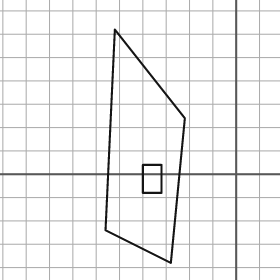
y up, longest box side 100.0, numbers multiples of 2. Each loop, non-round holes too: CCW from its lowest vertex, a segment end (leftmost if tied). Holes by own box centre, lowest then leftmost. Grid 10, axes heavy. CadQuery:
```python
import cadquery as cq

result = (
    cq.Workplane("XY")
    .moveTo(-28.0, -38.0)
    .lineTo(-22.0, 24.0)
    .lineTo(-52.0, 62.0)
    .lineTo(-56.0, -24.0)
    .close()
    .moveTo(-40.0, -8.0)
    .lineTo(-32.0, -8.0)
    .lineTo(-32.0, 4.0)
    .lineTo(-40.0, 4.0)
    .close()
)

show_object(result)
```